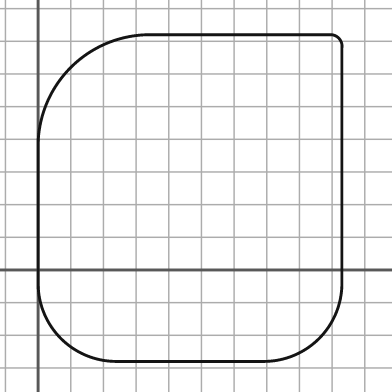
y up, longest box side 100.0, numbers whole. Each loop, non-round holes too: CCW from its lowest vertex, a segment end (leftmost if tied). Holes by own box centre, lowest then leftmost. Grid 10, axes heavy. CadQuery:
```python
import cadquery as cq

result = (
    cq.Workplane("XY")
    .moveTo(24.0, -28.0)
    .lineTo(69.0, -28.0)
    .threePointArc((86.0, -21.0), (93.0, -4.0))
    .lineTo(93.0, 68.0)
    .threePointArc((92.0, 71.0), (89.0, 72.0))
    .lineTo(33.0, 72.0)
    .threePointArc((10.0, 62.0), (0.0, 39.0))
    .lineTo(0.0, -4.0)
    .threePointArc((7.0, -21.0), (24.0, -28.0))
    .close()
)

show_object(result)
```